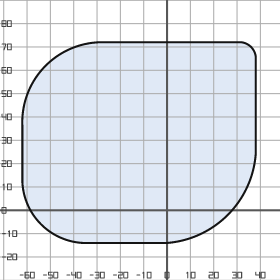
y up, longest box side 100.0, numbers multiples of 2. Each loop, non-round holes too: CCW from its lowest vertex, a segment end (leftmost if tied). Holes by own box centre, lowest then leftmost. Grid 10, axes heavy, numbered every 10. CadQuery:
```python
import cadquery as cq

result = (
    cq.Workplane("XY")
    .moveTo(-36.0, -14.0)
    .lineTo(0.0, -14.0)
    .threePointArc((26.0, -2.0), (38.0, 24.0))
    .lineTo(38.0, 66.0)
    .threePointArc((36.0, 70.0), (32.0, 72.0))
    .lineTo(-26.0, 72.0)
    .threePointArc((-52.0, 62.0), (-62.0, 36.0))
    .lineTo(-62.0, 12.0)
    .threePointArc((-54.0, -6.0), (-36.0, -14.0))
    .close()
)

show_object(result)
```